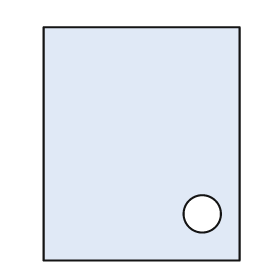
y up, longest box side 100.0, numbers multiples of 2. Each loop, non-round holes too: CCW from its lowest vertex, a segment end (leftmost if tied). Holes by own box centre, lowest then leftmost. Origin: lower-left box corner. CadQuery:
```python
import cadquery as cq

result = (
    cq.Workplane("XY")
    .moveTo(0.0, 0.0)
    .lineTo(84.0, 0.0)
    .lineTo(84.0, 100.0)
    .lineTo(0.0, 100.0)
    .close()
    .moveTo(68.0, 20.0)
    .circle(8.0)
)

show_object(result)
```